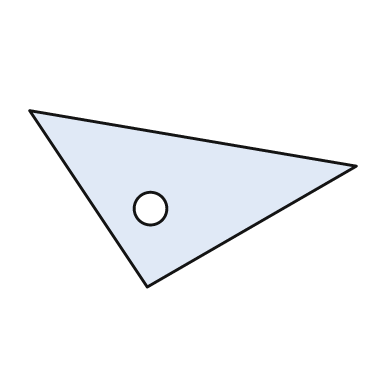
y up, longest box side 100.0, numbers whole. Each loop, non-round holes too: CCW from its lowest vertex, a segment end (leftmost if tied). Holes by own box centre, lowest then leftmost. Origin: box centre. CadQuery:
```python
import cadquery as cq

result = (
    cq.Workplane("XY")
    .moveTo(-14.0, -27.0)
    .lineTo(50.0, 10.0)
    .lineTo(-50.0, 27.0)
    .close()
    .moveTo(-13.0, -3.0)
    .circle(5.0)
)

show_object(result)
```